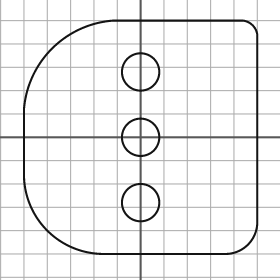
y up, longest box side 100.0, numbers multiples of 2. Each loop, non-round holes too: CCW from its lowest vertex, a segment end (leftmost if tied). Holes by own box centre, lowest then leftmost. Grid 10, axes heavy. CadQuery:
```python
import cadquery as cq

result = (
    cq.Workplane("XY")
    .moveTo(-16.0, -50.0)
    .lineTo(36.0, -50.0)
    .threePointArc((46.0, -46.0), (50.0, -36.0))
    .lineTo(50.0, 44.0)
    .threePointArc((48.0, 48.0), (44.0, 50.0))
    .lineTo(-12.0, 50.0)
    .threePointArc((-38.0, 38.0), (-50.0, 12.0))
    .lineTo(-50.0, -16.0)
    .threePointArc((-40.0, -40.0), (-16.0, -50.0))
    .close()
    .moveTo(0.0, -28.0)
    .circle(8.0)
    .moveTo(0.0, 0.0)
    .circle(8.0)
    .moveTo(0.0, 28.0)
    .circle(8.0)
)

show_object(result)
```